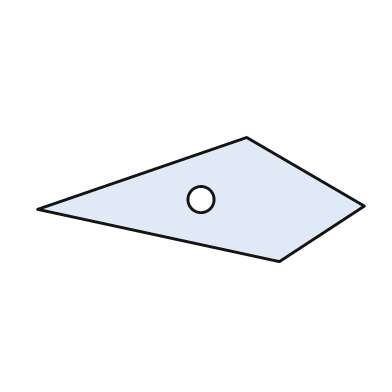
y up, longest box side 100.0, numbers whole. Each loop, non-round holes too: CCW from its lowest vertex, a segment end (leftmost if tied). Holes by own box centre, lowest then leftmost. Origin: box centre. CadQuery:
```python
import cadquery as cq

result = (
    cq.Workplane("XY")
    .moveTo(24.0, -19.0)
    .lineTo(50.0, -2.0)
    .lineTo(14.0, 19.0)
    .lineTo(-50.0, -3.0)
    .close()
    .moveTo(0.0, 0.0)
    .circle(4.0)
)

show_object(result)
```